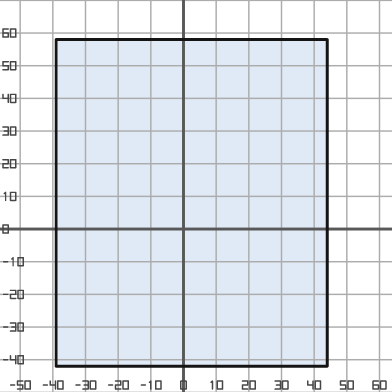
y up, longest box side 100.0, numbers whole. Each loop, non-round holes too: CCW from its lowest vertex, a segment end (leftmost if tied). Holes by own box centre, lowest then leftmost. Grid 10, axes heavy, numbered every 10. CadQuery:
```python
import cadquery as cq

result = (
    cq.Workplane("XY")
    .moveTo(-39.0, -42.0)
    .lineTo(44.0, -42.0)
    .lineTo(44.0, 58.0)
    .lineTo(-39.0, 58.0)
    .close()
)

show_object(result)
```